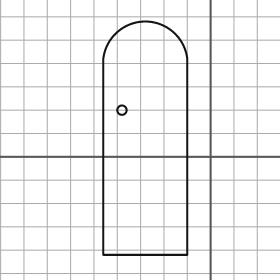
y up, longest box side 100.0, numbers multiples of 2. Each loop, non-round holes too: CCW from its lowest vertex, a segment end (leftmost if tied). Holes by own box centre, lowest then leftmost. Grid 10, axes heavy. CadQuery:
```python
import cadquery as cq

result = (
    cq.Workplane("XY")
    .moveTo(-46.0, -42.0)
    .lineTo(-10.0, -42.0)
    .lineTo(-10.0, 42.0)
    .threePointArc((-28.0, 58.0), (-46.0, 42.0))
    .close()
    .moveTo(-38.0, 20.0)
    .circle(2.0)
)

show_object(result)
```